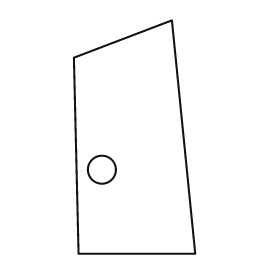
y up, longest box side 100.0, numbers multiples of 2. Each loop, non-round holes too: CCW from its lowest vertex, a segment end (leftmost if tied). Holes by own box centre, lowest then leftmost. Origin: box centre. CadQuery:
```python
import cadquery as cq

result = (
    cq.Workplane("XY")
    .moveTo(-24.0, -50.0)
    .lineTo(26.0, -50.0)
    .lineTo(16.0, 50.0)
    .lineTo(-26.0, 34.0)
    .close()
    .moveTo(-14.0, -14.0)
    .circle(6.0)
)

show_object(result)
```